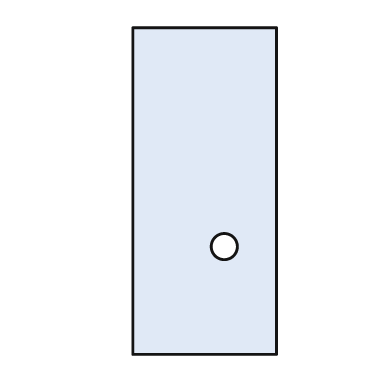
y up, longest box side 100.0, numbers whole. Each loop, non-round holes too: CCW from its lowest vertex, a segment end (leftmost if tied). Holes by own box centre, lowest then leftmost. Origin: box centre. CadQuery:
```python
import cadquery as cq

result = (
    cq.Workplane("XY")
    .moveTo(-22.0, -50.0)
    .lineTo(22.0, -50.0)
    .lineTo(22.0, 50.0)
    .lineTo(-22.0, 50.0)
    .close()
    .moveTo(6.0, -17.0)
    .circle(4.0)
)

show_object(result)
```